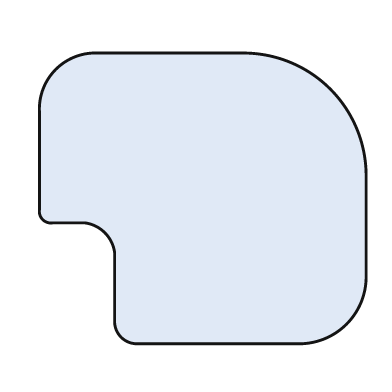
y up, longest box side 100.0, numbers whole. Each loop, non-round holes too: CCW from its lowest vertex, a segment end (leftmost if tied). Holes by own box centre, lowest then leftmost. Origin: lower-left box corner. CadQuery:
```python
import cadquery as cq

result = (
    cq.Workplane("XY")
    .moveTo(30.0, 0.0)
    .lineTo(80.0, 0.0)
    .threePointArc((94.0, 6.0), (100.0, 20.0))
    .lineTo(100.0, 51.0)
    .threePointArc((89.0, 78.0), (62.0, 89.0))
    .lineTo(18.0, 89.0)
    .threePointArc((5.0, 84.0), (0.0, 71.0))
    .lineTo(0.0, 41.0)
    .threePointArc((1.0, 38.0), (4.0, 37.0))
    .lineTo(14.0, 37.0)
    .threePointArc((20.0, 34.0), (23.0, 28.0))
    .lineTo(23.0, 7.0)
    .threePointArc((25.0, 2.0), (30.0, 0.0))
    .close()
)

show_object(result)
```